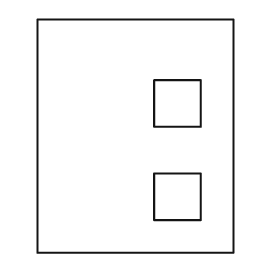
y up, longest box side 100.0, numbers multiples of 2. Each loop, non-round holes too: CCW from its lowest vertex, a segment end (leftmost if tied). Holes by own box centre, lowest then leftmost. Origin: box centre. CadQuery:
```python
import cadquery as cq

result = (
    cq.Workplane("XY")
    .moveTo(-42.0, -50.0)
    .lineTo(42.0, -50.0)
    .lineTo(42.0, 50.0)
    .lineTo(-42.0, 50.0)
    .close()
    .moveTo(8.0, -36.0)
    .lineTo(28.0, -36.0)
    .lineTo(28.0, -16.0)
    .lineTo(8.0, -16.0)
    .close()
    .moveTo(8.0, 4.0)
    .lineTo(28.0, 4.0)
    .lineTo(28.0, 24.0)
    .lineTo(8.0, 24.0)
    .close()
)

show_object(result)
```